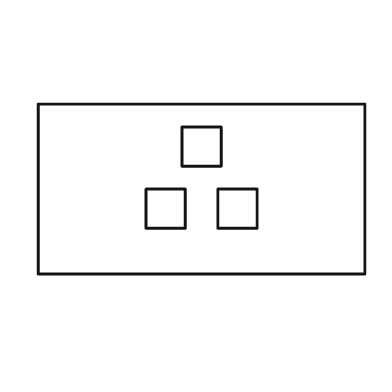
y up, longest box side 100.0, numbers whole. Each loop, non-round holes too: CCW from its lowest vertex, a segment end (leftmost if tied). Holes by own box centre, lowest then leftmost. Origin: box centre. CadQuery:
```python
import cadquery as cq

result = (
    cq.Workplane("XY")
    .moveTo(-50.0, -26.0)
    .lineTo(50.0, -26.0)
    .lineTo(50.0, 26.0)
    .lineTo(-50.0, 26.0)
    .close()
    .moveTo(-17.0, -12.0)
    .lineTo(-5.0, -12.0)
    .lineTo(-5.0, 0.0)
    .lineTo(-17.0, 0.0)
    .close()
    .moveTo(5.0, -12.0)
    .lineTo(17.0, -12.0)
    .lineTo(17.0, 0.0)
    .lineTo(5.0, 0.0)
    .close()
    .moveTo(-6.0, 7.0)
    .lineTo(6.0, 7.0)
    .lineTo(6.0, 19.0)
    .lineTo(-6.0, 19.0)
    .close()
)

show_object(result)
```